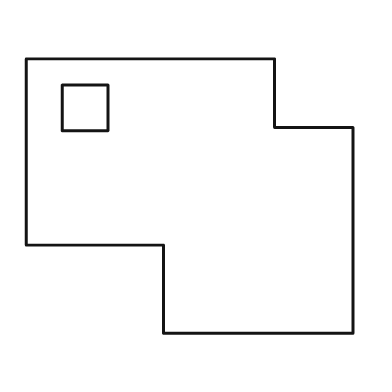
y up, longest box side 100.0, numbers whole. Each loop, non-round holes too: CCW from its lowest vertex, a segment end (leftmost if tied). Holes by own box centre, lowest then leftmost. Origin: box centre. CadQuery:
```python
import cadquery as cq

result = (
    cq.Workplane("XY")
    .moveTo(-8.0, -42.0)
    .lineTo(50.0, -42.0)
    .lineTo(50.0, 21.0)
    .lineTo(26.0, 21.0)
    .lineTo(26.0, 42.0)
    .lineTo(-50.0, 42.0)
    .lineTo(-50.0, -15.0)
    .lineTo(-8.0, -15.0)
    .close()
    .moveTo(-39.0, 20.0)
    .lineTo(-25.0, 20.0)
    .lineTo(-25.0, 34.0)
    .lineTo(-39.0, 34.0)
    .close()
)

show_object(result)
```